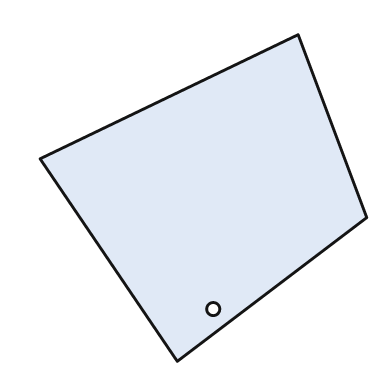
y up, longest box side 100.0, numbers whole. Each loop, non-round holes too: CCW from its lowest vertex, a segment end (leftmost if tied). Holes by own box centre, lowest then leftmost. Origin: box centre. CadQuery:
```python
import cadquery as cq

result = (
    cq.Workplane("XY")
    .moveTo(-8.0, -50.0)
    .lineTo(50.0, -6.0)
    .lineTo(29.0, 50.0)
    .lineTo(-50.0, 12.0)
    .close()
    .moveTo(3.0, -34.0)
    .circle(2.0)
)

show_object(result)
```